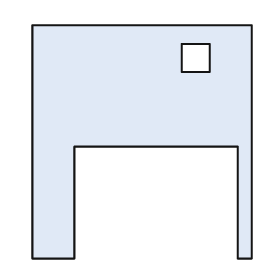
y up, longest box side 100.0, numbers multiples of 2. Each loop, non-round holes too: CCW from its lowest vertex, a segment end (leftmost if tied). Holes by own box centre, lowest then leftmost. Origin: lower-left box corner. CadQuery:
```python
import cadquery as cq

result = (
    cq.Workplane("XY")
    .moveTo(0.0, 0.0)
    .lineTo(18.0, 0.0)
    .lineTo(18.0, 48.0)
    .lineTo(88.0, 48.0)
    .lineTo(88.0, 0.0)
    .lineTo(94.0, 0.0)
    .lineTo(94.0, 100.0)
    .lineTo(0.0, 100.0)
    .close()
    .moveTo(64.0, 80.0)
    .lineTo(76.0, 80.0)
    .lineTo(76.0, 92.0)
    .lineTo(64.0, 92.0)
    .close()
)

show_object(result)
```